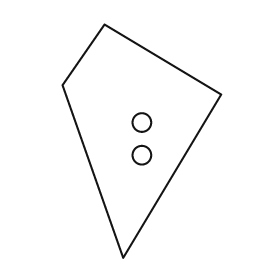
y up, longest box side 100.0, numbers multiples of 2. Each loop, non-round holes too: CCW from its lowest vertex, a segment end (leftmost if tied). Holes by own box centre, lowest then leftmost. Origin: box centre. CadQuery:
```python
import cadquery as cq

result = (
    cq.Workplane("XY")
    .moveTo(-8.0, -50.0)
    .lineTo(34.0, 20.0)
    .lineTo(-16.0, 50.0)
    .lineTo(-34.0, 24.0)
    .close()
    .moveTo(0.0, -6.0)
    .circle(4.0)
    .moveTo(0.0, 8.0)
    .circle(4.0)
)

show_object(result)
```